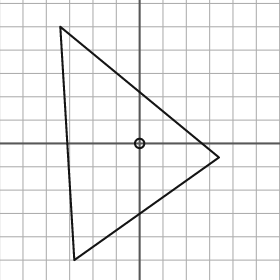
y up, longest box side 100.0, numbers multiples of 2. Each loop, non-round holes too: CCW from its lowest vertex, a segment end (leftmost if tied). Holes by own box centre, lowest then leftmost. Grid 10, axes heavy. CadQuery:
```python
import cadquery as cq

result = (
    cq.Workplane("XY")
    .moveTo(-28.0, -50.0)
    .lineTo(34.0, -6.0)
    .lineTo(-34.0, 50.0)
    .close()
    .moveTo(0.0, 0.0)
    .circle(2.0)
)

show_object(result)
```